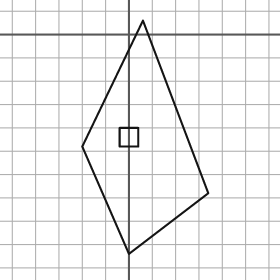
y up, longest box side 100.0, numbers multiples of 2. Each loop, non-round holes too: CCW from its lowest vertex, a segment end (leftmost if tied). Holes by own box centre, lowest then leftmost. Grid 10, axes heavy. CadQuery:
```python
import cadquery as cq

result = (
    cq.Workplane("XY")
    .moveTo(0.0, -94.0)
    .lineTo(34.0, -68.0)
    .lineTo(6.0, 6.0)
    .lineTo(-20.0, -48.0)
    .close()
    .moveTo(-4.0, -48.0)
    .lineTo(4.0, -48.0)
    .lineTo(4.0, -40.0)
    .lineTo(-4.0, -40.0)
    .close()
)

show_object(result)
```